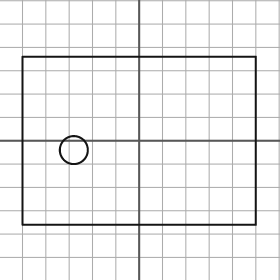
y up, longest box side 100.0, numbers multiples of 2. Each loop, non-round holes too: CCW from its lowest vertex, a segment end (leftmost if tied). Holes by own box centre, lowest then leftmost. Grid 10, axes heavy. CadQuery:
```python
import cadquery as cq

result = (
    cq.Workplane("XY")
    .moveTo(-50.0, -36.0)
    .lineTo(50.0, -36.0)
    .lineTo(50.0, 36.0)
    .lineTo(-50.0, 36.0)
    .close()
    .moveTo(-28.0, -4.0)
    .circle(6.0)
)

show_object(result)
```